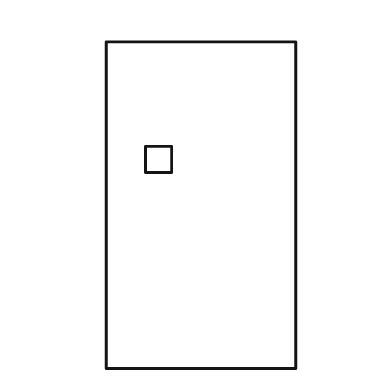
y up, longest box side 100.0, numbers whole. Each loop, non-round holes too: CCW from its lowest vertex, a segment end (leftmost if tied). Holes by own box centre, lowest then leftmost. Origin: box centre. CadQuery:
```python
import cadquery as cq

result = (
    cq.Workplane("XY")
    .moveTo(-29.0, -50.0)
    .lineTo(29.0, -50.0)
    .lineTo(29.0, 50.0)
    .lineTo(-29.0, 50.0)
    .close()
    .moveTo(-17.0, 10.0)
    .lineTo(-9.0, 10.0)
    .lineTo(-9.0, 18.0)
    .lineTo(-17.0, 18.0)
    .close()
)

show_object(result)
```